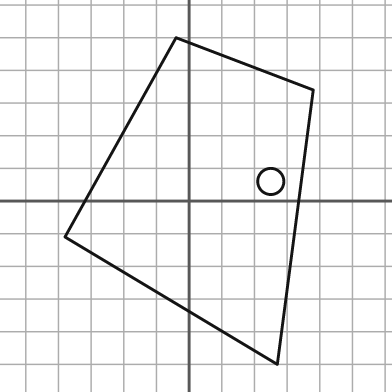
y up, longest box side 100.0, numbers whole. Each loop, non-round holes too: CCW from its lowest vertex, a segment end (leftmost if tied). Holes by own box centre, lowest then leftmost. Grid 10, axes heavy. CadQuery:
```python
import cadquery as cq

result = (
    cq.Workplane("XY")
    .moveTo(27.0, -50.0)
    .lineTo(38.0, 34.0)
    .lineTo(-4.0, 50.0)
    .lineTo(-38.0, -11.0)
    .close()
    .moveTo(25.0, 6.0)
    .circle(4.0)
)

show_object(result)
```